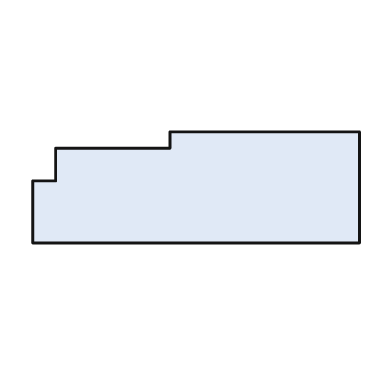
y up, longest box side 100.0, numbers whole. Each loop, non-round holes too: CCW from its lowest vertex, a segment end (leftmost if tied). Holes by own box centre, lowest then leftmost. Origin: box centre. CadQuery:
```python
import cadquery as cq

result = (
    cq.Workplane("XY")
    .moveTo(-50.0, -17.0)
    .lineTo(50.0, -17.0)
    .lineTo(50.0, 17.0)
    .lineTo(-8.0, 17.0)
    .lineTo(-8.0, 12.0)
    .lineTo(-43.0, 12.0)
    .lineTo(-43.0, 2.0)
    .lineTo(-50.0, 2.0)
    .close()
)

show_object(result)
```